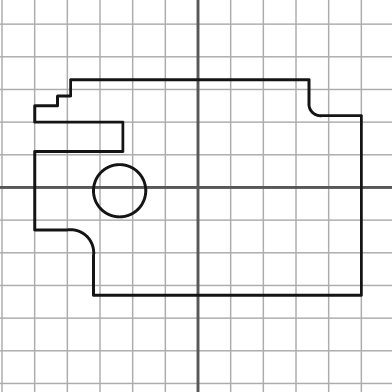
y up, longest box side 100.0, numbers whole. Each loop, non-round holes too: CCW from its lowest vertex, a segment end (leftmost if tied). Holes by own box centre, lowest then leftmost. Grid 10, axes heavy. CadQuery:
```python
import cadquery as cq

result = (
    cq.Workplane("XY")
    .moveTo(-32.0, -33.0)
    .lineTo(50.0, -33.0)
    .lineTo(50.0, 22.0)
    .lineTo(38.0, 22.0)
    .threePointArc((35.0, 23.0), (34.0, 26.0))
    .lineTo(34.0, 33.0)
    .lineTo(-39.0, 33.0)
    .lineTo(-39.0, 28.0)
    .lineTo(-43.0, 28.0)
    .lineTo(-43.0, 25.0)
    .lineTo(-50.0, 25.0)
    .lineTo(-50.0, 20.0)
    .lineTo(-23.0, 20.0)
    .lineTo(-23.0, 11.0)
    .lineTo(-50.0, 11.0)
    .lineTo(-50.0, -13.0)
    .lineTo(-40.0, -13.0)
    .threePointArc((-34.0, -15.0), (-32.0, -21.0))
    .close()
    .moveTo(-24.0, -1.0)
    .circle(8.0)
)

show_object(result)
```